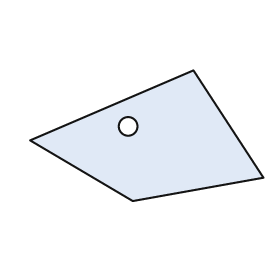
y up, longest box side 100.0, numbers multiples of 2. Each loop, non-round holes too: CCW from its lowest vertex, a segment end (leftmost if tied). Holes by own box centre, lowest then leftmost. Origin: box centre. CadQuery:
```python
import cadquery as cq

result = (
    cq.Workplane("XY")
    .moveTo(-6.0, -28.0)
    .lineTo(50.0, -18.0)
    .lineTo(20.0, 28.0)
    .lineTo(-50.0, -2.0)
    .close()
    .moveTo(-8.0, 4.0)
    .circle(4.0)
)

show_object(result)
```